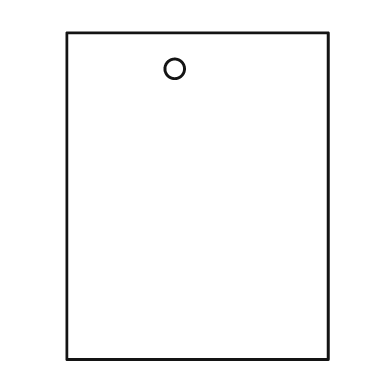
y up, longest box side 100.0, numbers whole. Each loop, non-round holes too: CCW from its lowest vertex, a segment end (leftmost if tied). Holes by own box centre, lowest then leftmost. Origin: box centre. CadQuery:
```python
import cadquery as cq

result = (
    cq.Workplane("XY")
    .moveTo(-40.0, -50.0)
    .lineTo(40.0, -50.0)
    .lineTo(40.0, 50.0)
    .lineTo(-40.0, 50.0)
    .close()
    .moveTo(-7.0, 39.0)
    .circle(3.0)
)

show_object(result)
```